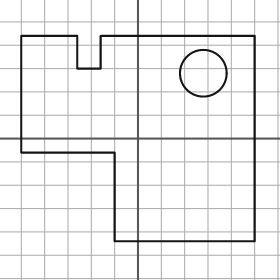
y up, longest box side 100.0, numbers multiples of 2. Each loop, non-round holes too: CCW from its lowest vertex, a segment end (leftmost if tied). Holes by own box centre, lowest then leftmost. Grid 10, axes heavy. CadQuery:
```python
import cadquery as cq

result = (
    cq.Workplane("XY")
    .moveTo(-10.0, -44.0)
    .lineTo(50.0, -44.0)
    .lineTo(50.0, 44.0)
    .lineTo(-16.0, 44.0)
    .lineTo(-16.0, 30.0)
    .lineTo(-26.0, 30.0)
    .lineTo(-26.0, 44.0)
    .lineTo(-50.0, 44.0)
    .lineTo(-50.0, -6.0)
    .lineTo(-10.0, -6.0)
    .close()
    .moveTo(28.0, 28.0)
    .circle(10.0)
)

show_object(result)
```